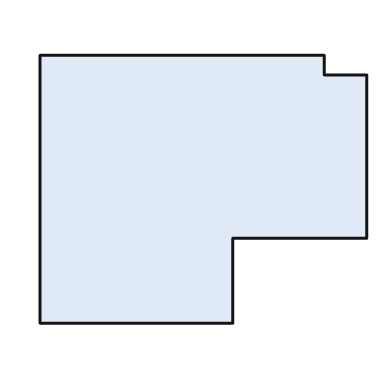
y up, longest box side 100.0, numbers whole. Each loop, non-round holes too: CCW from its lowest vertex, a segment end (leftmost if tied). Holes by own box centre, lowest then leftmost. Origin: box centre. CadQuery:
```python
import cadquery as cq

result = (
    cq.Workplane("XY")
    .moveTo(-50.0, -41.0)
    .lineTo(9.0, -41.0)
    .lineTo(9.0, -15.0)
    .lineTo(50.0, -15.0)
    .lineTo(50.0, 35.0)
    .lineTo(37.0, 35.0)
    .lineTo(37.0, 41.0)
    .lineTo(-50.0, 41.0)
    .close()
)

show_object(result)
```